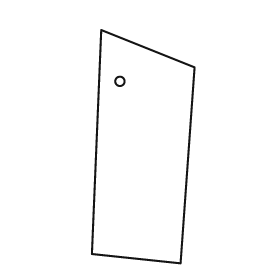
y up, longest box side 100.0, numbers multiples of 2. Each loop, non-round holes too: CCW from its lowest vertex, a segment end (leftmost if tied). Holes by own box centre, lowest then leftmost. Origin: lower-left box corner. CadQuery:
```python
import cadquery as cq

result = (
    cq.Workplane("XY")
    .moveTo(38.0, 0.0)
    .lineTo(44.0, 84.0)
    .lineTo(4.0, 100.0)
    .lineTo(0.0, 4.0)
    .close()
    .moveTo(12.0, 78.0)
    .circle(2.0)
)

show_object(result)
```